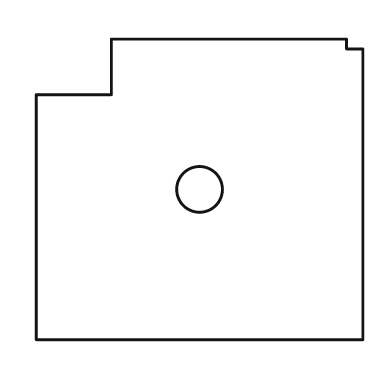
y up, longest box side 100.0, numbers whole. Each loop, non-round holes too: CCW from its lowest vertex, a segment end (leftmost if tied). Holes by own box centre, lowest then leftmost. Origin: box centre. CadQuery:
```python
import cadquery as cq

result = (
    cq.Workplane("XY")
    .moveTo(-50.0, -46.0)
    .lineTo(50.0, -46.0)
    .lineTo(50.0, 43.0)
    .lineTo(45.0, 43.0)
    .lineTo(45.0, 46.0)
    .lineTo(-27.0, 46.0)
    .lineTo(-27.0, 29.0)
    .lineTo(-50.0, 29.0)
    .close()
    .moveTo(0.0, 0.0)
    .circle(7.0)
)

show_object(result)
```